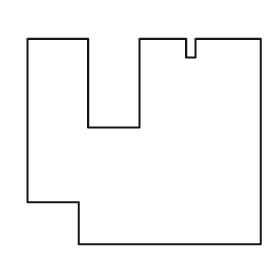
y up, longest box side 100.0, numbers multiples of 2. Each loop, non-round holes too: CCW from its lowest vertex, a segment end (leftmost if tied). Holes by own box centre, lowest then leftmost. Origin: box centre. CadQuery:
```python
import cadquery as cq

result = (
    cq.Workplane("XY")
    .moveTo(-28.0, -44.0)
    .lineTo(50.0, -44.0)
    .lineTo(50.0, 44.0)
    .lineTo(22.0, 44.0)
    .lineTo(22.0, 36.0)
    .lineTo(18.0, 36.0)
    .lineTo(18.0, 44.0)
    .lineTo(-2.0, 44.0)
    .lineTo(-2.0, 6.0)
    .lineTo(-24.0, 6.0)
    .lineTo(-24.0, 44.0)
    .lineTo(-50.0, 44.0)
    .lineTo(-50.0, -26.0)
    .lineTo(-28.0, -26.0)
    .close()
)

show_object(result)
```